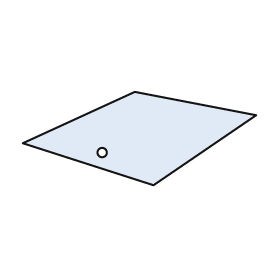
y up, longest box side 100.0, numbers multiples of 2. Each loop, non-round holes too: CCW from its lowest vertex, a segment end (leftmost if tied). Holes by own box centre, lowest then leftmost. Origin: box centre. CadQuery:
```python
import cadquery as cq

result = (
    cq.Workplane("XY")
    .moveTo(6.0, -20.0)
    .lineTo(50.0, 10.0)
    .lineTo(-2.0, 20.0)
    .lineTo(-50.0, -2.0)
    .close()
    .moveTo(-16.0, -6.0)
    .circle(2.0)
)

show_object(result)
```